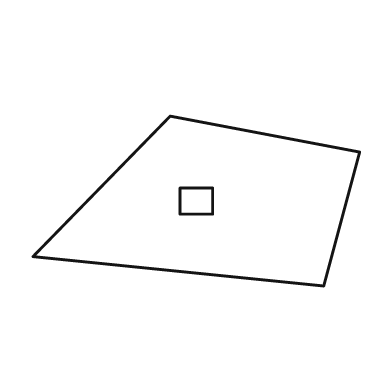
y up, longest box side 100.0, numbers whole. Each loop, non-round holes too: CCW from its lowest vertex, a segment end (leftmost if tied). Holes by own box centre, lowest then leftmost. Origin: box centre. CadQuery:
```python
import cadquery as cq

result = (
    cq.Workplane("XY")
    .moveTo(39.0, -26.0)
    .lineTo(50.0, 15.0)
    .lineTo(-8.0, 26.0)
    .lineTo(-50.0, -17.0)
    .close()
    .moveTo(-5.0, -4.0)
    .lineTo(5.0, -4.0)
    .lineTo(5.0, 4.0)
    .lineTo(-5.0, 4.0)
    .close()
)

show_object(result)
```